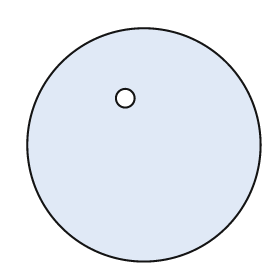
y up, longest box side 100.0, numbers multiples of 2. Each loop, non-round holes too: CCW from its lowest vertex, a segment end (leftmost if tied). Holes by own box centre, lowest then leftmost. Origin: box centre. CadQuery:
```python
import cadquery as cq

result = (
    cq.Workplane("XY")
    .moveTo(0.0, 0.0)
    .circle(50.0)
    .moveTo(-8.0, 20.0)
    .circle(4.0)
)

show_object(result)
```